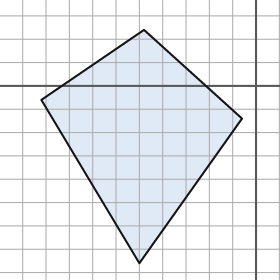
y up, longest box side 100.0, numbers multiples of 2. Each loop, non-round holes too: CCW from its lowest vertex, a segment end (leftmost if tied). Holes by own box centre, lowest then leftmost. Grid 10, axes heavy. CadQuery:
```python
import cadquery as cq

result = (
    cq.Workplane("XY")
    .moveTo(-50.0, -76.0)
    .lineTo(-6.0, -14.0)
    .lineTo(-48.0, 24.0)
    .lineTo(-92.0, -6.0)
    .close()
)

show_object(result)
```